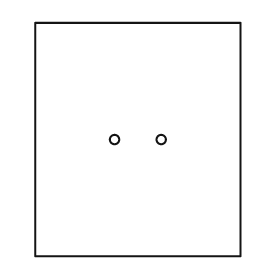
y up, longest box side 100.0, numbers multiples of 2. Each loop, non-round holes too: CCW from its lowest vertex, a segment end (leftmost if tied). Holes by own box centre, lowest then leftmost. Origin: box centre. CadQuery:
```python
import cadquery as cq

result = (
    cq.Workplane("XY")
    .moveTo(-44.0, -50.0)
    .lineTo(44.0, -50.0)
    .lineTo(44.0, 50.0)
    .lineTo(-44.0, 50.0)
    .close()
    .moveTo(-10.0, 0.0)
    .circle(2.0)
    .moveTo(10.0, 0.0)
    .circle(2.0)
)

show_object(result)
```